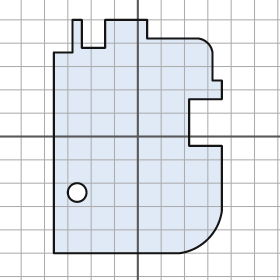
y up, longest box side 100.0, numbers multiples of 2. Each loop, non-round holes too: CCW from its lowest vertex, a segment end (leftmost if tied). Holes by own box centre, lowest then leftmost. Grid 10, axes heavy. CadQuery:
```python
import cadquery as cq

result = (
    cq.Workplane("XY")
    .moveTo(-36.0, -50.0)
    .lineTo(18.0, -50.0)
    .threePointArc((30.0, -44.0), (36.0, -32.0))
    .lineTo(36.0, -4.0)
    .lineTo(22.0, -4.0)
    .lineTo(22.0, 16.0)
    .lineTo(36.0, 16.0)
    .lineTo(36.0, 24.0)
    .lineTo(32.0, 24.0)
    .lineTo(32.0, 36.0)
    .threePointArc((30.0, 40.0), (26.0, 42.0))
    .lineTo(4.0, 42.0)
    .lineTo(4.0, 50.0)
    .lineTo(-14.0, 50.0)
    .lineTo(-14.0, 38.0)
    .lineTo(-24.0, 38.0)
    .lineTo(-24.0, 50.0)
    .lineTo(-28.0, 50.0)
    .lineTo(-28.0, 36.0)
    .lineTo(-36.0, 36.0)
    .close()
    .moveTo(-26.0, -24.0)
    .circle(4.0)
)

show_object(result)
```